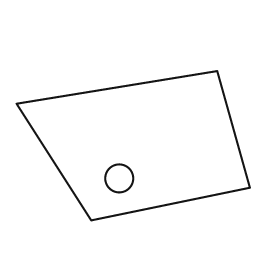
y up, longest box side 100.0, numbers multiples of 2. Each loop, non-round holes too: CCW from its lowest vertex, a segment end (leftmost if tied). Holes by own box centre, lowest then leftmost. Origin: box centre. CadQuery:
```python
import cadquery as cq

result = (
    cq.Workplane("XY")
    .moveTo(-18.0, -32.0)
    .lineTo(50.0, -18.0)
    .lineTo(36.0, 32.0)
    .lineTo(-50.0, 18.0)
    .close()
    .moveTo(-6.0, -14.0)
    .circle(6.0)
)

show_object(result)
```